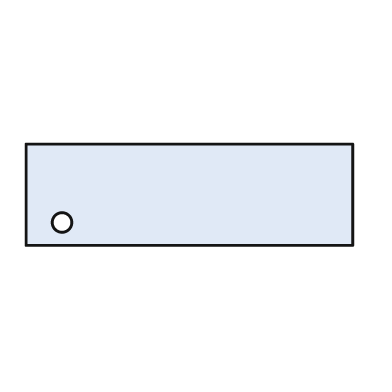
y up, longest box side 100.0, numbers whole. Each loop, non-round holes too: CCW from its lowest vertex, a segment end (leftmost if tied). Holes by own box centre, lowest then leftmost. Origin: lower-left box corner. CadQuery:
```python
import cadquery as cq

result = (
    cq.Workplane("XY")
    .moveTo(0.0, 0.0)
    .lineTo(100.0, 0.0)
    .lineTo(100.0, 31.0)
    .lineTo(0.0, 31.0)
    .close()
    .moveTo(11.0, 7.0)
    .circle(3.0)
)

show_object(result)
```